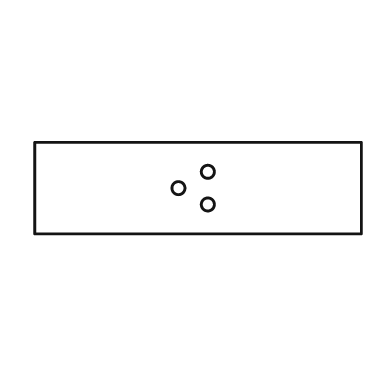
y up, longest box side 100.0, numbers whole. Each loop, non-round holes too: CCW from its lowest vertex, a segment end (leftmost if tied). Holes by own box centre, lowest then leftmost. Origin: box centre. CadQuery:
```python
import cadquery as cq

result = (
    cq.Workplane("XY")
    .moveTo(-50.0, -14.0)
    .lineTo(50.0, -14.0)
    .lineTo(50.0, 14.0)
    .lineTo(-50.0, 14.0)
    .close()
    .moveTo(3.0, -5.0)
    .circle(2.0)
    .moveTo(-6.0, 0.0)
    .circle(2.0)
    .moveTo(3.0, 5.0)
    .circle(2.0)
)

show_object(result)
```